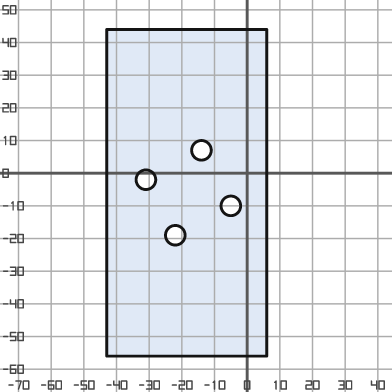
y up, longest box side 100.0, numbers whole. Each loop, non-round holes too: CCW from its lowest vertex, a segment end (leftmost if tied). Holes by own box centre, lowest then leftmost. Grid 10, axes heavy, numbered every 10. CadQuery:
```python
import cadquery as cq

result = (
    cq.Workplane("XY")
    .moveTo(-43.0, -56.0)
    .lineTo(6.0, -56.0)
    .lineTo(6.0, 44.0)
    .lineTo(-43.0, 44.0)
    .close()
    .moveTo(-22.0, -19.0)
    .circle(3.0)
    .moveTo(-5.0, -10.0)
    .circle(3.0)
    .moveTo(-31.0, -2.0)
    .circle(3.0)
    .moveTo(-14.0, 7.0)
    .circle(3.0)
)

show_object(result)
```